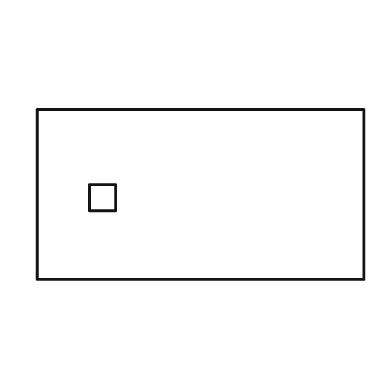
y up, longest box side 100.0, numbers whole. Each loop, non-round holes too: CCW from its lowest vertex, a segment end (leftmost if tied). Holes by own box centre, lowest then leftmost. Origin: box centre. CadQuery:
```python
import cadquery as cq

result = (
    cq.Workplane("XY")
    .moveTo(-50.0, -26.0)
    .lineTo(50.0, -26.0)
    .lineTo(50.0, 26.0)
    .lineTo(-50.0, 26.0)
    .close()
    .moveTo(-34.0, -5.0)
    .lineTo(-26.0, -5.0)
    .lineTo(-26.0, 3.0)
    .lineTo(-34.0, 3.0)
    .close()
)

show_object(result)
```